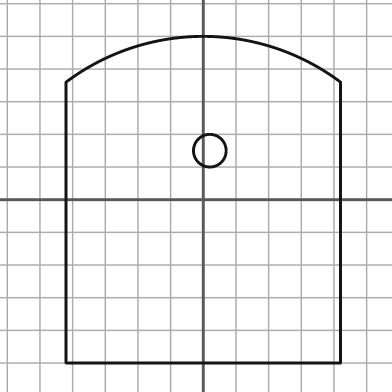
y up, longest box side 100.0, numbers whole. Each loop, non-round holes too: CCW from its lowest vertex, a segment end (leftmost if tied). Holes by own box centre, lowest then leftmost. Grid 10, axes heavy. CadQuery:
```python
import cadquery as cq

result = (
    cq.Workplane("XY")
    .moveTo(-42.0, -50.0)
    .lineTo(42.0, -50.0)
    .lineTo(42.0, 36.0)
    .threePointArc((0.0, 50.0), (-42.0, 36.0))
    .close()
    .moveTo(2.0, 15.0)
    .circle(5.0)
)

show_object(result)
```